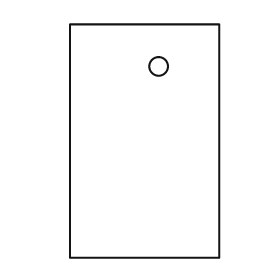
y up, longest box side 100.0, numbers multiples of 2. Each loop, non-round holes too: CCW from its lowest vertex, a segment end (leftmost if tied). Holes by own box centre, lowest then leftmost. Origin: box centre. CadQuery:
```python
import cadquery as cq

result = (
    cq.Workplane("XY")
    .moveTo(-32.0, -50.0)
    .lineTo(32.0, -50.0)
    .lineTo(32.0, 50.0)
    .lineTo(-32.0, 50.0)
    .close()
    .moveTo(6.0, 32.0)
    .circle(4.0)
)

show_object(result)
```